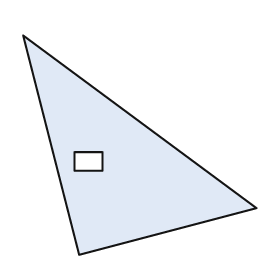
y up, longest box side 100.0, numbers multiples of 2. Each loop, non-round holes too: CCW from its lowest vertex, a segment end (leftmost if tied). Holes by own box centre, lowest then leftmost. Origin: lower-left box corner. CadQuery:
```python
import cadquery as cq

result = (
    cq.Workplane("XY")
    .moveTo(24.0, 0.0)
    .lineTo(100.0, 20.0)
    .lineTo(0.0, 94.0)
    .close()
    .moveTo(22.0, 36.0)
    .lineTo(34.0, 36.0)
    .lineTo(34.0, 44.0)
    .lineTo(22.0, 44.0)
    .close()
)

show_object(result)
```